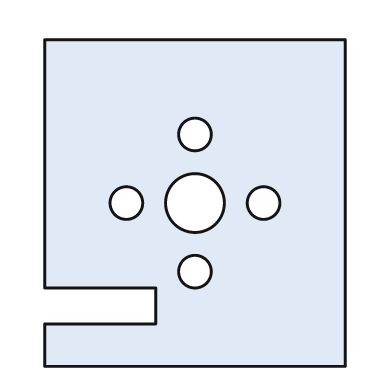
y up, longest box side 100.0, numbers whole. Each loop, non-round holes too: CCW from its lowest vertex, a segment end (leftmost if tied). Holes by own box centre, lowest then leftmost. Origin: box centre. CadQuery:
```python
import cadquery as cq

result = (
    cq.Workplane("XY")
    .moveTo(-46.0, -50.0)
    .lineTo(46.0, -50.0)
    .lineTo(46.0, 50.0)
    .lineTo(-46.0, 50.0)
    .lineTo(-46.0, -26.0)
    .lineTo(-12.0, -26.0)
    .lineTo(-12.0, -37.0)
    .lineTo(-46.0, -37.0)
    .close()
    .moveTo(0.0, -21.0)
    .circle(5.0)
    .moveTo(-21.0, 0.0)
    .circle(5.0)
    .moveTo(0.0, 0.0)
    .circle(9.0)
    .moveTo(21.0, 0.0)
    .circle(5.0)
    .moveTo(0.0, 21.0)
    .circle(5.0)
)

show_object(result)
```